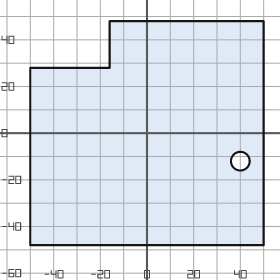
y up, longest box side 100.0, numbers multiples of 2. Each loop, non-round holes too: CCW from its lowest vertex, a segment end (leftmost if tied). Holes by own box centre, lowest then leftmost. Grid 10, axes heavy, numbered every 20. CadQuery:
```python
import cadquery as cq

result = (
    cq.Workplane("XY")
    .moveTo(-50.0, -48.0)
    .lineTo(50.0, -48.0)
    .lineTo(50.0, 48.0)
    .lineTo(-16.0, 48.0)
    .lineTo(-16.0, 28.0)
    .lineTo(-50.0, 28.0)
    .close()
    .moveTo(40.0, -12.0)
    .circle(4.0)
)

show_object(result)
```